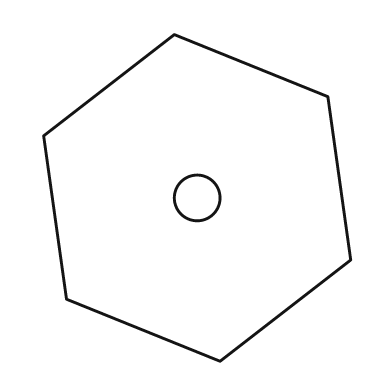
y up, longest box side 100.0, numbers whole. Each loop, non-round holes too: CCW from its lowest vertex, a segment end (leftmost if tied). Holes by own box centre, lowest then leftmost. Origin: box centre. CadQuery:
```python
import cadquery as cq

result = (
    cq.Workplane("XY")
    .moveTo(7.0, -50.0)
    .lineTo(47.0, -19.0)
    .lineTo(40.0, 31.0)
    .lineTo(-7.0, 50.0)
    .lineTo(-47.0, 19.0)
    .lineTo(-40.0, -31.0)
    .close()
    .moveTo(0.0, 0.0)
    .circle(7.0)
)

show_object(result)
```